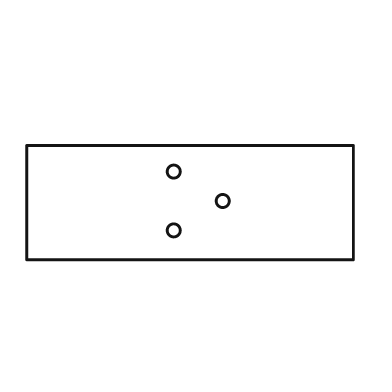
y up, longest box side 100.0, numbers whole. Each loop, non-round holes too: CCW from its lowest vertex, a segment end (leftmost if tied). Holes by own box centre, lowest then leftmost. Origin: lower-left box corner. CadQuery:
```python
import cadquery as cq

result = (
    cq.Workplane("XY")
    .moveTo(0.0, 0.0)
    .lineTo(100.0, 0.0)
    .lineTo(100.0, 35.0)
    .lineTo(0.0, 35.0)
    .close()
    .moveTo(45.0, 9.0)
    .circle(2.0)
    .moveTo(60.0, 18.0)
    .circle(2.0)
    .moveTo(45.0, 27.0)
    .circle(2.0)
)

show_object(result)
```